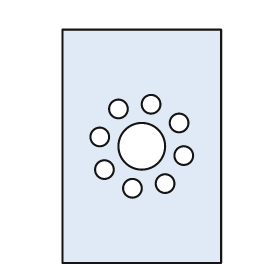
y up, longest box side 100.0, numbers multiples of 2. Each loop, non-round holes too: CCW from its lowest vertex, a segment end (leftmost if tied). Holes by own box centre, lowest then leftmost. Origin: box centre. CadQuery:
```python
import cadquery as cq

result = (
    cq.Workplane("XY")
    .moveTo(-34.0, -50.0)
    .lineTo(34.0, -50.0)
    .lineTo(34.0, 50.0)
    .lineTo(-34.0, 50.0)
    .close()
    .moveTo(-4.0, -18.0)
    .circle(4.0)
    .moveTo(10.0, -16.0)
    .circle(4.0)
    .moveTo(-16.0, -10.0)
    .circle(4.0)
    .moveTo(18.0, -4.0)
    .circle(4.0)
    .moveTo(0.0, 0.0)
    .circle(10.0)
    .moveTo(-18.0, 4.0)
    .circle(4.0)
    .moveTo(16.0, 10.0)
    .circle(4.0)
    .moveTo(-10.0, 16.0)
    .circle(4.0)
    .moveTo(4.0, 18.0)
    .circle(4.0)
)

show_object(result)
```